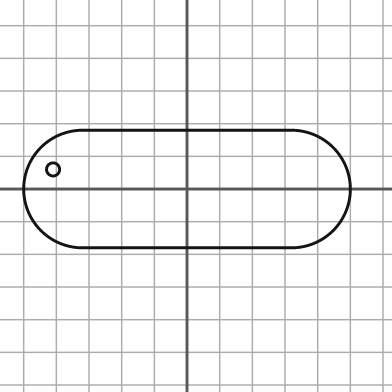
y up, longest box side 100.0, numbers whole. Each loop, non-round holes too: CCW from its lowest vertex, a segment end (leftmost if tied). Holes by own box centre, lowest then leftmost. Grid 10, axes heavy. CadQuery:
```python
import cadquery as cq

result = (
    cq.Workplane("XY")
    .moveTo(-32.0, -18.0)
    .lineTo(32.0, -18.0)
    .threePointArc((50.0, 0.0), (32.0, 18.0))
    .lineTo(-32.0, 18.0)
    .threePointArc((-50.0, 0.0), (-32.0, -18.0))
    .close()
    .moveTo(-41.0, 6.0)
    .circle(2.0)
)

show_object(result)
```